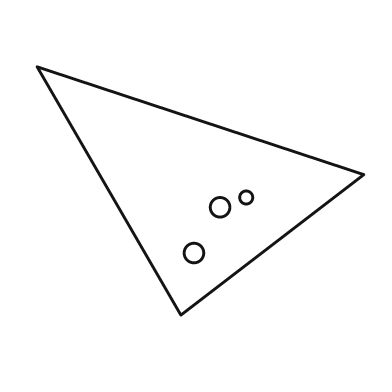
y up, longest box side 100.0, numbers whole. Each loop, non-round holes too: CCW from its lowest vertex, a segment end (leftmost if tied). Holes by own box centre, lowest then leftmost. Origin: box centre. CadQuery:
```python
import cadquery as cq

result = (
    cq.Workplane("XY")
    .moveTo(-6.0, -38.0)
    .lineTo(50.0, 5.0)
    .lineTo(-50.0, 38.0)
    .close()
    .moveTo(-2.0, -19.0)
    .circle(3.0)
    .moveTo(6.0, -5.0)
    .circle(3.0)
    .moveTo(14.0, -2.0)
    .circle(2.0)
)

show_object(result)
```